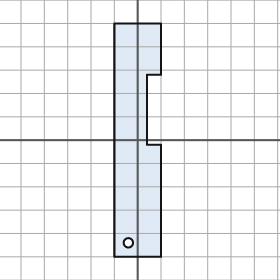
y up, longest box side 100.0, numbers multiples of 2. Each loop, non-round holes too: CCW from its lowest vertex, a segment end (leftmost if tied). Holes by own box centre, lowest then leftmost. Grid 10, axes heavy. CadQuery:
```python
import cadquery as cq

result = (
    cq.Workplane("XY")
    .moveTo(-10.0, -50.0)
    .lineTo(10.0, -50.0)
    .lineTo(10.0, -2.0)
    .lineTo(4.0, -2.0)
    .lineTo(4.0, 28.0)
    .lineTo(10.0, 28.0)
    .lineTo(10.0, 50.0)
    .lineTo(-10.0, 50.0)
    .close()
    .moveTo(-4.0, -44.0)
    .circle(2.0)
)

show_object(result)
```